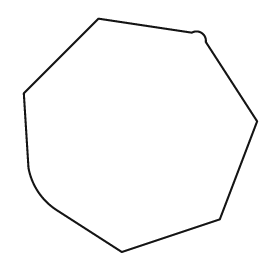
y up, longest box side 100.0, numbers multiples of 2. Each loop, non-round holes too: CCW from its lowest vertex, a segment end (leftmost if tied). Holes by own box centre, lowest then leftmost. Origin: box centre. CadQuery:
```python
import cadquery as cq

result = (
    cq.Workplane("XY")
    .moveTo(-8.0, -50.0)
    .lineTo(34.0, -36.0)
    .lineTo(50.0, 6.0)
    .lineTo(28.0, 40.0)
    .threePointArc((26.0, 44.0), (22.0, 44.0))
    .lineTo(-18.0, 50.0)
    .lineTo(-50.0, 18.0)
    .lineTo(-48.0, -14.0)
    .threePointArc((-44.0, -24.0), (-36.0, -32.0))
    .close()
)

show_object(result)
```